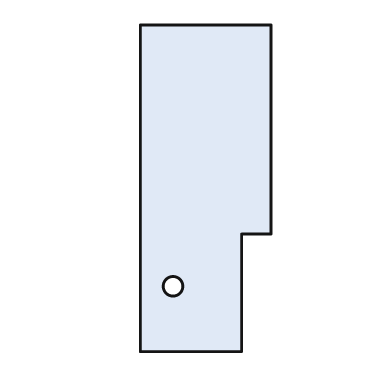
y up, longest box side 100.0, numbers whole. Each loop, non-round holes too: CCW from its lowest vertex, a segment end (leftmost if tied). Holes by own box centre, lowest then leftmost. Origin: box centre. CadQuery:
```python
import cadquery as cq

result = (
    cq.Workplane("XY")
    .moveTo(-20.0, -50.0)
    .lineTo(11.0, -50.0)
    .lineTo(11.0, -14.0)
    .lineTo(20.0, -14.0)
    .lineTo(20.0, 50.0)
    .lineTo(-20.0, 50.0)
    .close()
    .moveTo(-10.0, -30.0)
    .circle(3.0)
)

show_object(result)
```